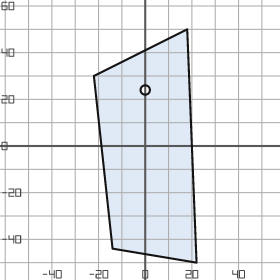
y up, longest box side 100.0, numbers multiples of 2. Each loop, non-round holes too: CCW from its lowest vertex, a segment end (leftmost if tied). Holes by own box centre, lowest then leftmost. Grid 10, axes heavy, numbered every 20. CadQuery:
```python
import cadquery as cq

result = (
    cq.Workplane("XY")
    .moveTo(22.0, -50.0)
    .lineTo(18.0, 50.0)
    .lineTo(-22.0, 30.0)
    .lineTo(-14.0, -44.0)
    .close()
    .moveTo(0.0, 24.0)
    .circle(2.0)
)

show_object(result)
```